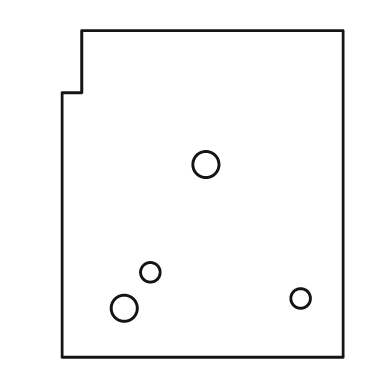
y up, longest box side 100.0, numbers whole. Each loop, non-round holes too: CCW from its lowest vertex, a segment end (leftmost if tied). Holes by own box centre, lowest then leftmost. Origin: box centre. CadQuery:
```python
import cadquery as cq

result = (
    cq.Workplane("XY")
    .moveTo(-43.0, -50.0)
    .lineTo(43.0, -50.0)
    .lineTo(43.0, 50.0)
    .lineTo(-37.0, 50.0)
    .lineTo(-37.0, 31.0)
    .lineTo(-43.0, 31.0)
    .close()
    .moveTo(-24.0, -35.0)
    .circle(4.0)
    .moveTo(30.0, -32.0)
    .circle(3.0)
    .moveTo(-16.0, -24.0)
    .circle(3.0)
    .moveTo(1.0, 9.0)
    .circle(4.0)
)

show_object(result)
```